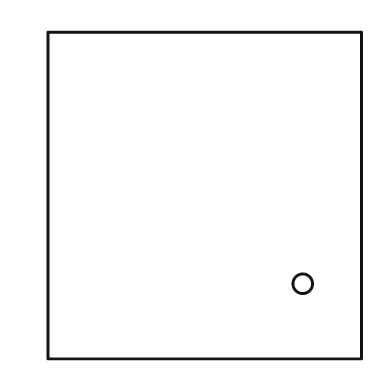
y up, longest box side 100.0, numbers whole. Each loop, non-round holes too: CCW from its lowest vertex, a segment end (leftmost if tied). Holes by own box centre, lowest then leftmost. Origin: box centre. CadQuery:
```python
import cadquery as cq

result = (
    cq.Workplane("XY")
    .moveTo(-48.0, -50.0)
    .lineTo(48.0, -50.0)
    .lineTo(48.0, 50.0)
    .lineTo(-48.0, 50.0)
    .close()
    .moveTo(30.0, -27.0)
    .circle(3.0)
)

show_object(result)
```